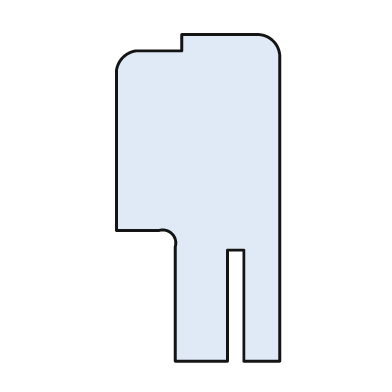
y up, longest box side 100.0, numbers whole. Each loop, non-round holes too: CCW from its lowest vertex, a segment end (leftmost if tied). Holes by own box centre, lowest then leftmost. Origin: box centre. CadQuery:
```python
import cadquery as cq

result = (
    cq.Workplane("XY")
    .moveTo(-7.0, -50.0)
    .lineTo(9.0, -50.0)
    .lineTo(9.0, -16.0)
    .lineTo(14.0, -16.0)
    .lineTo(14.0, -50.0)
    .lineTo(25.0, -50.0)
    .lineTo(25.0, 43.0)
    .threePointArc((23.0, 48.0), (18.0, 50.0))
    .lineTo(-5.0, 50.0)
    .lineTo(-5.0, 45.0)
    .lineTo(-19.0, 45.0)
    .threePointArc((-23.0, 43.0), (-25.0, 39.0))
    .lineTo(-25.0, -10.0)
    .lineTo(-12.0, -10.0)
    .threePointArc((-8.0, -11.0), (-7.0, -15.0))
    .close()
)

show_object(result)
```